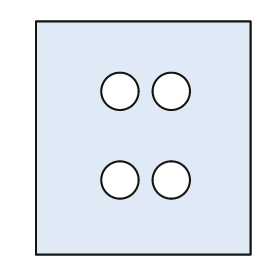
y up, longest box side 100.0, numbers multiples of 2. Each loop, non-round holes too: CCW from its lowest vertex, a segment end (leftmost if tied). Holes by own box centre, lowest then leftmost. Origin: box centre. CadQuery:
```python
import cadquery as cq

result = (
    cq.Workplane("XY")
    .moveTo(-46.0, -50.0)
    .lineTo(46.0, -50.0)
    .lineTo(46.0, 50.0)
    .lineTo(-46.0, 50.0)
    .close()
    .moveTo(-10.0, -18.0)
    .circle(8.0)
    .moveTo(12.0, -18.0)
    .circle(8.0)
    .moveTo(-10.0, 20.0)
    .circle(8.0)
    .moveTo(12.0, 20.0)
    .circle(8.0)
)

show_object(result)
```